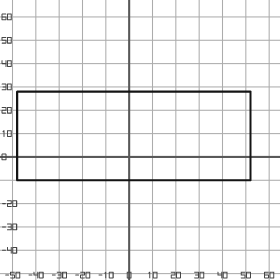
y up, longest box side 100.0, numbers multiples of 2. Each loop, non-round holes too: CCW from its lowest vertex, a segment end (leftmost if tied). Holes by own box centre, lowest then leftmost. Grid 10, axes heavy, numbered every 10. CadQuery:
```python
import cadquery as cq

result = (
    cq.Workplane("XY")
    .moveTo(-48.0, -10.0)
    .lineTo(52.0, -10.0)
    .lineTo(52.0, 28.0)
    .lineTo(-48.0, 28.0)
    .close()
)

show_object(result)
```